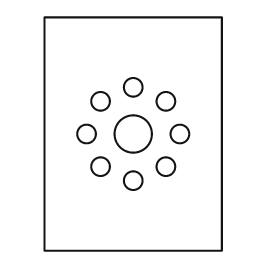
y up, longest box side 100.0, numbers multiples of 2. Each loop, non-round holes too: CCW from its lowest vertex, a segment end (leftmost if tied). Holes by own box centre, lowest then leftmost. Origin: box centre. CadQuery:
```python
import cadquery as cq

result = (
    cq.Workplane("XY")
    .moveTo(-38.0, -50.0)
    .lineTo(38.0, -50.0)
    .lineTo(38.0, 50.0)
    .lineTo(-38.0, 50.0)
    .close()
    .moveTo(0.0, -20.0)
    .circle(4.0)
    .moveTo(-14.0, -14.0)
    .circle(4.0)
    .moveTo(14.0, -14.0)
    .circle(4.0)
    .moveTo(-20.0, 0.0)
    .circle(4.0)
    .moveTo(0.0, 0.0)
    .circle(8.0)
    .moveTo(20.0, 0.0)
    .circle(4.0)
    .moveTo(-14.0, 14.0)
    .circle(4.0)
    .moveTo(14.0, 14.0)
    .circle(4.0)
    .moveTo(0.0, 20.0)
    .circle(4.0)
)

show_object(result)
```